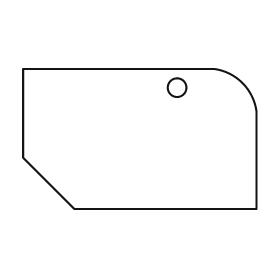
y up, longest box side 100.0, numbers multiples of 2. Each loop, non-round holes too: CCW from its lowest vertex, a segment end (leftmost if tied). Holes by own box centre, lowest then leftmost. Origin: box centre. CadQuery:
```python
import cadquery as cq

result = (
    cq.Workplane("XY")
    .moveTo(-28.0, -30.0)
    .lineTo(50.0, -30.0)
    .lineTo(50.0, 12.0)
    .threePointArc((44.0, 24.0), (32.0, 30.0))
    .lineTo(-50.0, 30.0)
    .lineTo(-50.0, -8.0)
    .close()
    .moveTo(16.0, 22.0)
    .circle(4.0)
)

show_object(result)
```